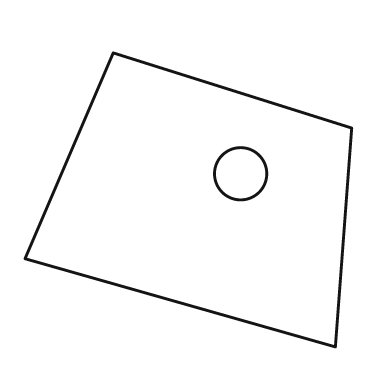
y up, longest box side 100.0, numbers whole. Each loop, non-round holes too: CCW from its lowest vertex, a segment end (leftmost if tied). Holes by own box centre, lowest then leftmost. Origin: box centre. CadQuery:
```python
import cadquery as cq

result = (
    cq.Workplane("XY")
    .moveTo(45.0, -45.0)
    .lineTo(50.0, 22.0)
    .lineTo(-23.0, 45.0)
    .lineTo(-50.0, -18.0)
    .close()
    .moveTo(16.0, 8.0)
    .circle(8.0)
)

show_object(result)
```